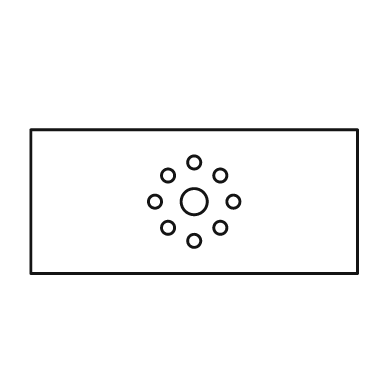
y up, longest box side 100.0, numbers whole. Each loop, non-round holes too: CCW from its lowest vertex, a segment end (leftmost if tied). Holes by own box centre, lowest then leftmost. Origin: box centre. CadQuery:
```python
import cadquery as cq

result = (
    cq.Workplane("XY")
    .moveTo(-50.0, -22.0)
    .lineTo(50.0, -22.0)
    .lineTo(50.0, 22.0)
    .lineTo(-50.0, 22.0)
    .close()
    .moveTo(0.0, -12.0)
    .circle(2.0)
    .moveTo(-8.0, -8.0)
    .circle(2.0)
    .moveTo(8.0, -8.0)
    .circle(2.0)
    .moveTo(-12.0, 0.0)
    .circle(2.0)
    .moveTo(0.0, 0.0)
    .circle(4.0)
    .moveTo(12.0, 0.0)
    .circle(2.0)
    .moveTo(-8.0, 8.0)
    .circle(2.0)
    .moveTo(8.0, 8.0)
    .circle(2.0)
    .moveTo(0.0, 12.0)
    .circle(2.0)
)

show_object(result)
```